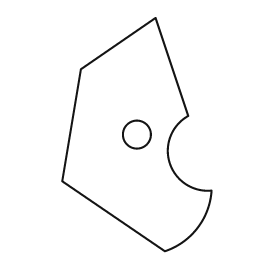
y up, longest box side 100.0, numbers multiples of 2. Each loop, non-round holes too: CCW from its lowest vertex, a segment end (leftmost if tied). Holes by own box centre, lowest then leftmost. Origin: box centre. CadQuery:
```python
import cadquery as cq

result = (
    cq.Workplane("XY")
    .moveTo(12.0, -50.0)
    .threePointArc((26.0, -40.0), (32.0, -24.0))
    .threePointArc((14.0, -12.0), (22.0, 8.0))
    .lineTo(8.0, 50.0)
    .lineTo(-24.0, 28.0)
    .lineTo(-32.0, -20.0)
    .close()
    .moveTo(0.0, 0.0)
    .circle(6.0)
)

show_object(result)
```